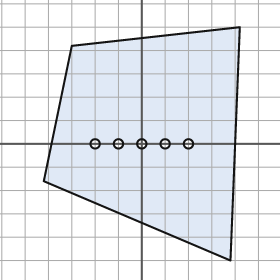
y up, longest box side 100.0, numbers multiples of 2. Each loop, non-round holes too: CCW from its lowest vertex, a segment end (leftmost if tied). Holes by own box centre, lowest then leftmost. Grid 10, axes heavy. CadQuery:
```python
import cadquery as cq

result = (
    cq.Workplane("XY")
    .moveTo(38.0, -50.0)
    .lineTo(42.0, 50.0)
    .lineTo(-30.0, 42.0)
    .lineTo(-42.0, -16.0)
    .close()
    .moveTo(-20.0, 0.0)
    .circle(2.0)
    .moveTo(-10.0, 0.0)
    .circle(2.0)
    .moveTo(0.0, 0.0)
    .circle(2.0)
    .moveTo(10.0, 0.0)
    .circle(2.0)
    .moveTo(20.0, 0.0)
    .circle(2.0)
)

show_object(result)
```